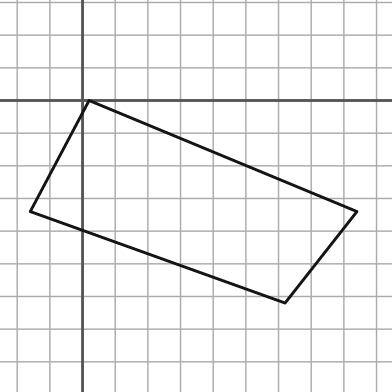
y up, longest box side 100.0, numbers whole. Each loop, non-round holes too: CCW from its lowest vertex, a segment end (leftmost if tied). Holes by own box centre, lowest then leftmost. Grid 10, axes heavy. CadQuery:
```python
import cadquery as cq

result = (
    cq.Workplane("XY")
    .moveTo(62.0, -62.0)
    .lineTo(84.0, -34.0)
    .lineTo(2.0, 0.0)
    .lineTo(-16.0, -34.0)
    .close()
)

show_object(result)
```